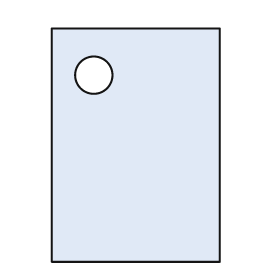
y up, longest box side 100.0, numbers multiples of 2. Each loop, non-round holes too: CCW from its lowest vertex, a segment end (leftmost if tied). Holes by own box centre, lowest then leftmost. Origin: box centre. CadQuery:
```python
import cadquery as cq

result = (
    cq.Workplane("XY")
    .moveTo(-36.0, -50.0)
    .lineTo(36.0, -50.0)
    .lineTo(36.0, 50.0)
    .lineTo(-36.0, 50.0)
    .close()
    .moveTo(-18.0, 30.0)
    .circle(8.0)
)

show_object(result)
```